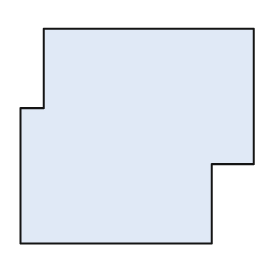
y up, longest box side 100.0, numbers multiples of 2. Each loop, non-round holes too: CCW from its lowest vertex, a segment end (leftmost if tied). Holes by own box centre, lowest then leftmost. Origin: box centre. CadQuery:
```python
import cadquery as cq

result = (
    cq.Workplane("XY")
    .moveTo(-50.0, -46.0)
    .lineTo(32.0, -46.0)
    .lineTo(32.0, -12.0)
    .lineTo(50.0, -12.0)
    .lineTo(50.0, 46.0)
    .lineTo(-40.0, 46.0)
    .lineTo(-40.0, 12.0)
    .lineTo(-50.0, 12.0)
    .close()
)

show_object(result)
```